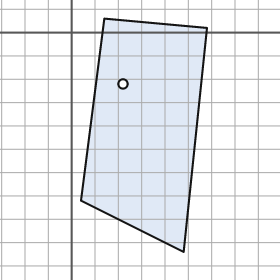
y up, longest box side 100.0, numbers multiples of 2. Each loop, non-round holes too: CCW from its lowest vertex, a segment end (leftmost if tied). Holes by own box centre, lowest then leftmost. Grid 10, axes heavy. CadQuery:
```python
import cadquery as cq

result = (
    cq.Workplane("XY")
    .moveTo(48.0, -94.0)
    .lineTo(58.0, 2.0)
    .lineTo(14.0, 6.0)
    .lineTo(4.0, -72.0)
    .close()
    .moveTo(22.0, -22.0)
    .circle(2.0)
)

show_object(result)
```